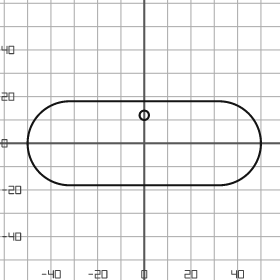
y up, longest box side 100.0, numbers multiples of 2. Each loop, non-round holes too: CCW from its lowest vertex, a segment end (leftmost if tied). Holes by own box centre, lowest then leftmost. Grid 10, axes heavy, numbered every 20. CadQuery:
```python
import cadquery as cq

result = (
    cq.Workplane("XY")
    .moveTo(-32.0, -18.0)
    .lineTo(32.0, -18.0)
    .threePointArc((50.0, 0.0), (32.0, 18.0))
    .lineTo(-32.0, 18.0)
    .threePointArc((-50.0, 0.0), (-32.0, -18.0))
    .close()
    .moveTo(0.0, 12.0)
    .circle(2.0)
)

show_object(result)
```